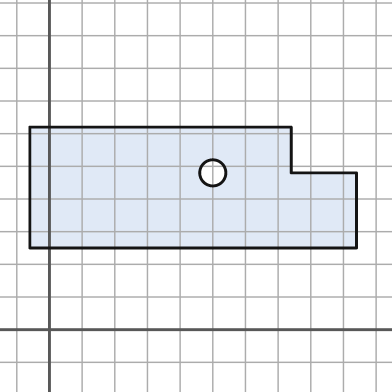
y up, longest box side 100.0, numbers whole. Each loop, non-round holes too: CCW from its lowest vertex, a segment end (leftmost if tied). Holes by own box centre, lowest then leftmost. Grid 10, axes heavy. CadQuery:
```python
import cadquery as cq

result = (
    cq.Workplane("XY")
    .moveTo(-6.0, 25.0)
    .lineTo(94.0, 25.0)
    .lineTo(94.0, 48.0)
    .lineTo(74.0, 48.0)
    .lineTo(74.0, 62.0)
    .lineTo(-6.0, 62.0)
    .close()
    .moveTo(50.0, 48.0)
    .circle(4.0)
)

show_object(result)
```